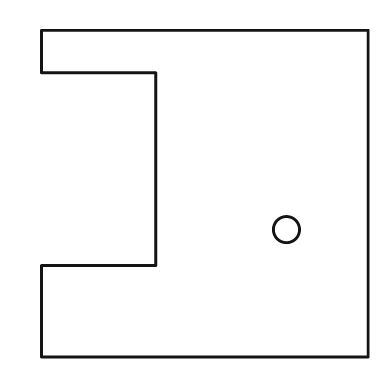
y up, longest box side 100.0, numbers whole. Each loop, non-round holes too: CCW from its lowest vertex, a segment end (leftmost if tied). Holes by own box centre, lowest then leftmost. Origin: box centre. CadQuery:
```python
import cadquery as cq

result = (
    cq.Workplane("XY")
    .moveTo(-50.0, -50.0)
    .lineTo(50.0, -50.0)
    .lineTo(50.0, 50.0)
    .lineTo(-50.0, 50.0)
    .lineTo(-50.0, 37.0)
    .lineTo(-15.0, 37.0)
    .lineTo(-15.0, -22.0)
    .lineTo(-50.0, -22.0)
    .close()
    .moveTo(25.0, -11.0)
    .circle(4.0)
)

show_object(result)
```